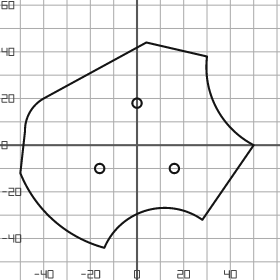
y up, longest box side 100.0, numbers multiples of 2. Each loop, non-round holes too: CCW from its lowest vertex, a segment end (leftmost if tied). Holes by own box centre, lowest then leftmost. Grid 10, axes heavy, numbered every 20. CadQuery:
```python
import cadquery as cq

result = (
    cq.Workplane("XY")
    .moveTo(-14.0, -44.0)
    .threePointArc((4.0, -28.0), (28.0, -32.0))
    .lineTo(50.0, 0.0)
    .threePointArc((34.0, 16.0), (30.0, 38.0))
    .lineTo(4.0, 44.0)
    .lineTo(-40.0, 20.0)
    .threePointArc((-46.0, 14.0), (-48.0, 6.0))
    .lineTo(-50.0, -12.0)
    .threePointArc((-36.0, -32.0), (-14.0, -44.0))
    .close()
    .moveTo(-16.0, -10.0)
    .circle(2.0)
    .moveTo(16.0, -10.0)
    .circle(2.0)
    .moveTo(0.0, 18.0)
    .circle(2.0)
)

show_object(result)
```